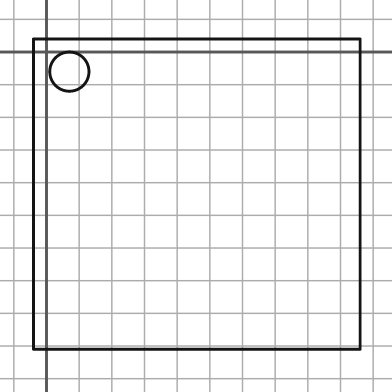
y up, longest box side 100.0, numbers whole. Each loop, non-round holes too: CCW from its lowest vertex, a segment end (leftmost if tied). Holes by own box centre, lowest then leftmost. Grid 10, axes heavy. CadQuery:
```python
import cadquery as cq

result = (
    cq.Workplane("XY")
    .moveTo(-4.0, -91.0)
    .lineTo(96.0, -91.0)
    .lineTo(96.0, 4.0)
    .lineTo(-4.0, 4.0)
    .close()
    .moveTo(7.0, -6.0)
    .circle(6.0)
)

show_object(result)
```